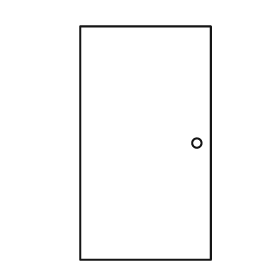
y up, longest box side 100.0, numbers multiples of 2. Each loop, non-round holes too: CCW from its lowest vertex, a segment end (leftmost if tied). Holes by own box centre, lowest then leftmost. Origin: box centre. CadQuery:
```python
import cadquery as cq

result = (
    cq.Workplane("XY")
    .moveTo(-28.0, -50.0)
    .lineTo(28.0, -50.0)
    .lineTo(28.0, 50.0)
    .lineTo(-28.0, 50.0)
    .close()
    .moveTo(22.0, 0.0)
    .circle(2.0)
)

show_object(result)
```